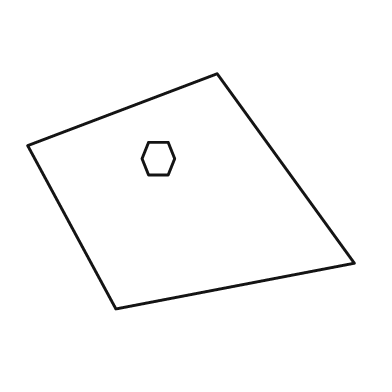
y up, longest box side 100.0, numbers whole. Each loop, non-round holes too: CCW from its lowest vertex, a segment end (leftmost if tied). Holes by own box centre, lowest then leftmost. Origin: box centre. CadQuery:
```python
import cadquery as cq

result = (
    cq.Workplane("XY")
    .moveTo(-23.0, -36.0)
    .lineTo(50.0, -22.0)
    .lineTo(8.0, 36.0)
    .lineTo(-50.0, 14.0)
    .close()
    .moveTo(-13.0, 5.0)
    .lineTo(-7.0, 5.0)
    .lineTo(-5.0, 10.0)
    .lineTo(-7.0, 15.0)
    .lineTo(-13.0, 15.0)
    .lineTo(-15.0, 10.0)
    .close()
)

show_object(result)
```